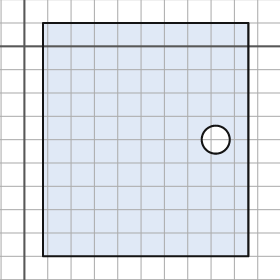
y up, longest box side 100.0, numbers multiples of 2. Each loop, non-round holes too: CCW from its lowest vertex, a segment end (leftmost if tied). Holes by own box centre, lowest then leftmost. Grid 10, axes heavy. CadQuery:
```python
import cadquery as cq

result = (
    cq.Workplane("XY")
    .moveTo(8.0, -90.0)
    .lineTo(96.0, -90.0)
    .lineTo(96.0, 10.0)
    .lineTo(8.0, 10.0)
    .close()
    .moveTo(82.0, -40.0)
    .circle(6.0)
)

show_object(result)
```